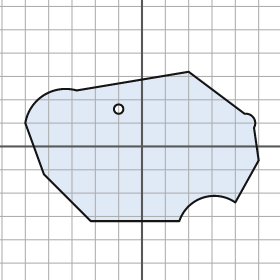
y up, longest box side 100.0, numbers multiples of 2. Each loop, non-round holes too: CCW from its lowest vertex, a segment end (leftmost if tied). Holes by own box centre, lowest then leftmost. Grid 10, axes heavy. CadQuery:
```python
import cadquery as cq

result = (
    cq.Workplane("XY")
    .moveTo(-22.0, -32.0)
    .lineTo(16.0, -32.0)
    .threePointArc((26.0, -22.0), (40.0, -24.0))
    .lineTo(50.0, -6.0)
    .lineTo(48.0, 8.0)
    .threePointArc((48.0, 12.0), (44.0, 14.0))
    .lineTo(20.0, 32.0)
    .lineTo(-28.0, 24.0)
    .threePointArc((-42.0, 22.0), (-50.0, 10.0))
    .lineTo(-42.0, -12.0)
    .close()
    .moveTo(-10.0, 16.0)
    .circle(2.0)
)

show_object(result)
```